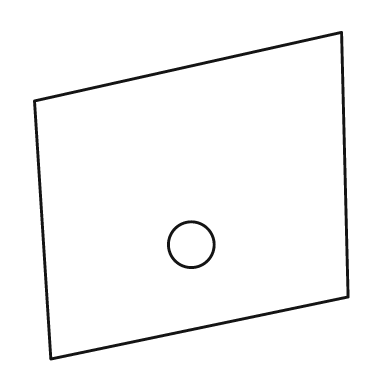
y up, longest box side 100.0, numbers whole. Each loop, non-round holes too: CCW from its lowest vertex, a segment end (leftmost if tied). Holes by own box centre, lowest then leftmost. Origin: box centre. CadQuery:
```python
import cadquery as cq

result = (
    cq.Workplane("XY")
    .moveTo(-43.0, -50.0)
    .lineTo(48.0, -31.0)
    .lineTo(46.0, 50.0)
    .lineTo(-48.0, 29.0)
    .close()
    .moveTo(0.0, -15.0)
    .circle(7.0)
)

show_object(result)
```